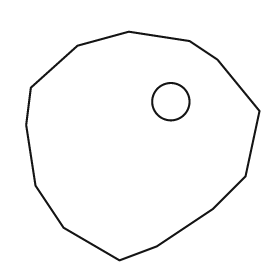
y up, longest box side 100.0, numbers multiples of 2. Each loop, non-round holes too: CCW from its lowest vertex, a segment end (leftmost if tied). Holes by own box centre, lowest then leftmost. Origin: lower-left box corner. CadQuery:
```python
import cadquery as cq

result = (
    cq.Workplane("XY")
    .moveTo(40.0, 0.0)
    .lineTo(56.0, 6.0)
    .lineTo(80.0, 22.0)
    .lineTo(94.0, 36.0)
    .lineTo(100.0, 64.0)
    .lineTo(82.0, 86.0)
    .lineTo(70.0, 94.0)
    .lineTo(44.0, 98.0)
    .lineTo(22.0, 92.0)
    .lineTo(2.0, 74.0)
    .lineTo(0.0, 58.0)
    .lineTo(4.0, 32.0)
    .lineTo(16.0, 14.0)
    .close()
    .moveTo(62.0, 68.0)
    .circle(8.0)
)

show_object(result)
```